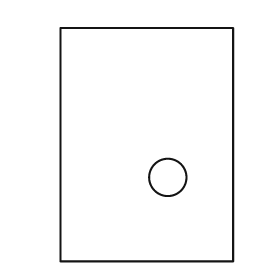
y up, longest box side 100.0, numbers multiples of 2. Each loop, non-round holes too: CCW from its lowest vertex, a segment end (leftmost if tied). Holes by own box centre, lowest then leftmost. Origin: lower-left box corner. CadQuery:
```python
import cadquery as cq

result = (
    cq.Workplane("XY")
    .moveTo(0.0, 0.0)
    .lineTo(74.0, 0.0)
    .lineTo(74.0, 100.0)
    .lineTo(0.0, 100.0)
    .close()
    .moveTo(46.0, 36.0)
    .circle(8.0)
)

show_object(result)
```